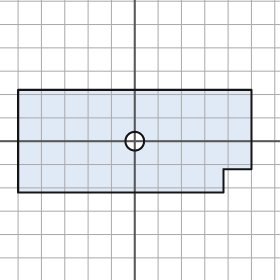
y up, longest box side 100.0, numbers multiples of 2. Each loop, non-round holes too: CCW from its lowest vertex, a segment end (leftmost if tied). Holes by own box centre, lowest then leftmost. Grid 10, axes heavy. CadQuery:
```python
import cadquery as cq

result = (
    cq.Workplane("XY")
    .moveTo(-50.0, -22.0)
    .lineTo(38.0, -22.0)
    .lineTo(38.0, -12.0)
    .lineTo(50.0, -12.0)
    .lineTo(50.0, 22.0)
    .lineTo(-50.0, 22.0)
    .close()
    .moveTo(0.0, 0.0)
    .circle(4.0)
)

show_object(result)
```